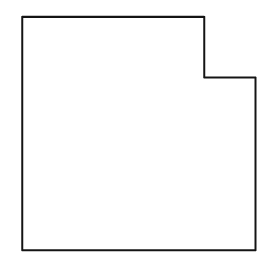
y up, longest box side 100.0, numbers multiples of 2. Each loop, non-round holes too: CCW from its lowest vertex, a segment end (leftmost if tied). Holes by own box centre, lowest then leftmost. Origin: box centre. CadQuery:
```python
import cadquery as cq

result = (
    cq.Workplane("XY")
    .moveTo(-50.0, -50.0)
    .lineTo(50.0, -50.0)
    .lineTo(50.0, 24.0)
    .lineTo(28.0, 24.0)
    .lineTo(28.0, 50.0)
    .lineTo(-50.0, 50.0)
    .close()
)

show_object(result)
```